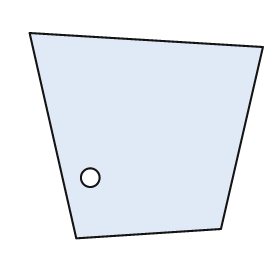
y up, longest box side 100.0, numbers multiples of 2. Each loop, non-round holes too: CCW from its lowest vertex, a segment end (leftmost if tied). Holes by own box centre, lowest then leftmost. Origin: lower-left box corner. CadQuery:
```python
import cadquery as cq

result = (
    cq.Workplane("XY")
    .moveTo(20.0, 0.0)
    .lineTo(82.0, 4.0)
    .lineTo(100.0, 82.0)
    .lineTo(0.0, 88.0)
    .close()
    .moveTo(26.0, 26.0)
    .circle(4.0)
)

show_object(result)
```